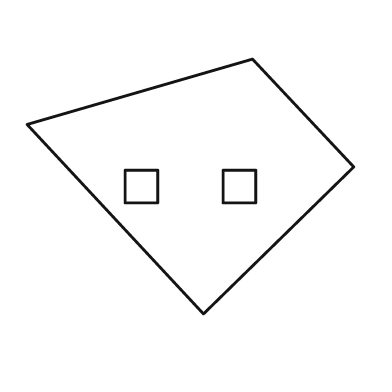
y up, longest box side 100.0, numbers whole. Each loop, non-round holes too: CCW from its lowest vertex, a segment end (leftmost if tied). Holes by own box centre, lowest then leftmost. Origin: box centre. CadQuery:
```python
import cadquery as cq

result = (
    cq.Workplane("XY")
    .moveTo(4.0, -39.0)
    .lineTo(50.0, 6.0)
    .lineTo(19.0, 39.0)
    .lineTo(-50.0, 19.0)
    .close()
    .moveTo(-20.0, -5.0)
    .lineTo(-10.0, -5.0)
    .lineTo(-10.0, 5.0)
    .lineTo(-20.0, 5.0)
    .close()
    .moveTo(10.0, -5.0)
    .lineTo(20.0, -5.0)
    .lineTo(20.0, 5.0)
    .lineTo(10.0, 5.0)
    .close()
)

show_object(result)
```